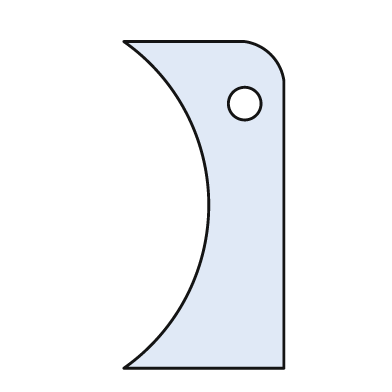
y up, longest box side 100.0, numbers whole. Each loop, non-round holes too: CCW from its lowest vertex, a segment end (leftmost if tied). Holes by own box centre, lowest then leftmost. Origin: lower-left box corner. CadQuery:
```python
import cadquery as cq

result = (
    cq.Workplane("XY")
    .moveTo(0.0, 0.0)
    .lineTo(49.0, 0.0)
    .lineTo(49.0, 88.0)
    .threePointArc((45.0, 96.0), (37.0, 100.0))
    .lineTo(0.0, 100.0)
    .threePointArc((26.0, 50.0), (0.0, 0.0))
    .close()
    .moveTo(37.0, 81.0)
    .circle(5.0)
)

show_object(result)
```